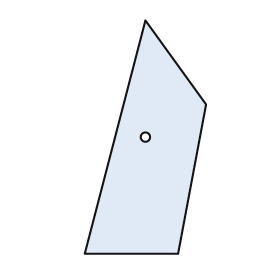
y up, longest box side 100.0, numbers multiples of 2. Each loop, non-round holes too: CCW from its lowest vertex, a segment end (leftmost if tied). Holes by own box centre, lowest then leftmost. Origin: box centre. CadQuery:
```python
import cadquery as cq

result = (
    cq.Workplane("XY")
    .moveTo(-26.0, -50.0)
    .lineTo(14.0, -50.0)
    .lineTo(26.0, 14.0)
    .lineTo(0.0, 50.0)
    .close()
    .moveTo(0.0, 0.0)
    .circle(2.0)
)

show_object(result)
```